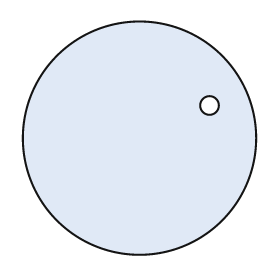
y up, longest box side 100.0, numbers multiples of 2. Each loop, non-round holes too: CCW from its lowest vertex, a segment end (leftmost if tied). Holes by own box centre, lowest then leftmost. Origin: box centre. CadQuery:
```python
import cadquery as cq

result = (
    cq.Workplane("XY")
    .moveTo(0.0, 0.0)
    .circle(50.0)
    .moveTo(30.0, 14.0)
    .circle(4.0)
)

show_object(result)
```